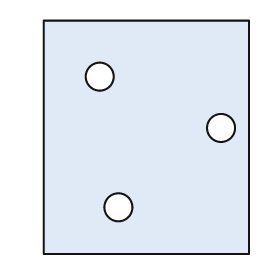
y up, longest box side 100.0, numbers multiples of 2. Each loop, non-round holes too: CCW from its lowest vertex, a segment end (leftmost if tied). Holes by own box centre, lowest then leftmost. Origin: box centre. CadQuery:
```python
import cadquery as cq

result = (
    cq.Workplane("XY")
    .moveTo(-44.0, -50.0)
    .lineTo(44.0, -50.0)
    .lineTo(44.0, 50.0)
    .lineTo(-44.0, 50.0)
    .close()
    .moveTo(-12.0, -30.0)
    .circle(6.0)
    .moveTo(32.0, 4.0)
    .circle(6.0)
    .moveTo(-20.0, 26.0)
    .circle(6.0)
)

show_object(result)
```